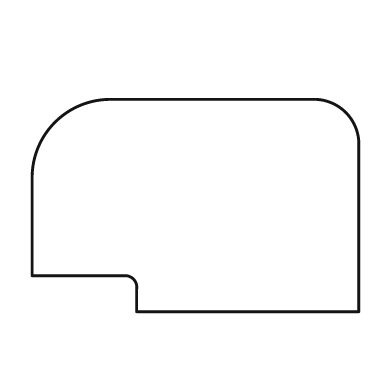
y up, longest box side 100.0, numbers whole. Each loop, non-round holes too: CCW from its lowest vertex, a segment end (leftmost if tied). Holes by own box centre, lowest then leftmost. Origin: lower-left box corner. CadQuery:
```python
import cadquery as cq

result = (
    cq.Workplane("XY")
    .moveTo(32.0, 0.0)
    .lineTo(100.0, 0.0)
    .lineTo(100.0, 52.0)
    .threePointArc((96.0, 61.0), (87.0, 65.0))
    .lineTo(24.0, 65.0)
    .threePointArc((7.0, 58.0), (0.0, 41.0))
    .lineTo(0.0, 11.0)
    .lineTo(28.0, 11.0)
    .threePointArc((31.0, 10.0), (32.0, 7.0))
    .close()
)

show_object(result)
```